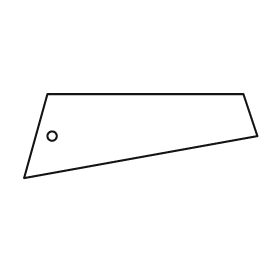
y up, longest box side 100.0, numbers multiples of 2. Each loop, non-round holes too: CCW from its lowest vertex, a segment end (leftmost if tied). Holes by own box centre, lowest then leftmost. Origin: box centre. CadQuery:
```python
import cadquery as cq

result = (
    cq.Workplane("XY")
    .moveTo(-50.0, -18.0)
    .lineTo(50.0, 0.0)
    .lineTo(44.0, 18.0)
    .lineTo(-40.0, 18.0)
    .close()
    .moveTo(-38.0, 0.0)
    .circle(2.0)
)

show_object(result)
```